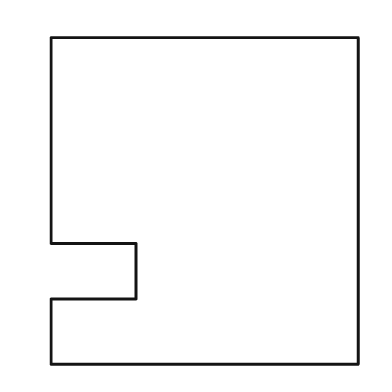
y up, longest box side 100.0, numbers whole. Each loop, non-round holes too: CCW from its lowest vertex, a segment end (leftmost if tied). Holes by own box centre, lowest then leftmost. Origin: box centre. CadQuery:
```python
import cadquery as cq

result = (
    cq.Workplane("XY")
    .moveTo(-47.0, -50.0)
    .lineTo(47.0, -50.0)
    .lineTo(47.0, 50.0)
    .lineTo(-47.0, 50.0)
    .lineTo(-47.0, -13.0)
    .lineTo(-21.0, -13.0)
    .lineTo(-21.0, -30.0)
    .lineTo(-47.0, -30.0)
    .close()
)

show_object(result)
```